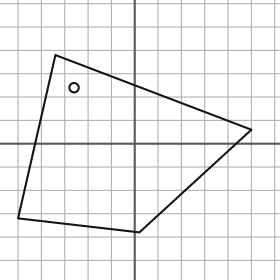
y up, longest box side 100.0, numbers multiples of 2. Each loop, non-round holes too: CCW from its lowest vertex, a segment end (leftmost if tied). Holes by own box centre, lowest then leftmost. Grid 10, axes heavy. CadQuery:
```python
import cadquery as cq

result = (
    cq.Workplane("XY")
    .moveTo(2.0, -38.0)
    .lineTo(50.0, 6.0)
    .lineTo(-34.0, 38.0)
    .lineTo(-50.0, -32.0)
    .close()
    .moveTo(-26.0, 24.0)
    .circle(2.0)
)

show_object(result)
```